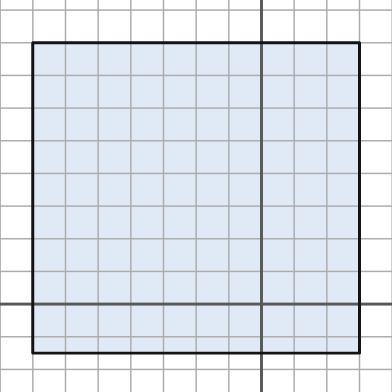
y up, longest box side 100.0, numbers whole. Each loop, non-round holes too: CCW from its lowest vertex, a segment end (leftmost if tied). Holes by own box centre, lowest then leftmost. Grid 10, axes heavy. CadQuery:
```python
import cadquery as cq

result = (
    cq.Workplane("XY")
    .moveTo(-70.0, -15.0)
    .lineTo(30.0, -15.0)
    .lineTo(30.0, 80.0)
    .lineTo(-70.0, 80.0)
    .close()
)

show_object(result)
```